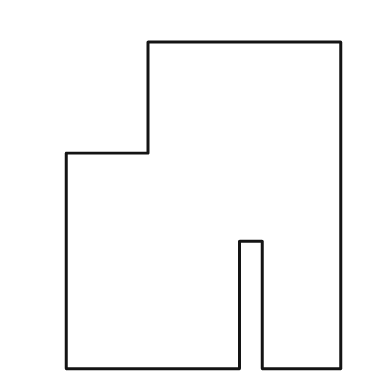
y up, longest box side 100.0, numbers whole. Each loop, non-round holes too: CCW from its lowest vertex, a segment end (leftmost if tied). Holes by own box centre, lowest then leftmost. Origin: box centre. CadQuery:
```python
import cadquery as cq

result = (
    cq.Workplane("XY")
    .moveTo(-42.0, -50.0)
    .lineTo(11.0, -50.0)
    .lineTo(11.0, -11.0)
    .lineTo(18.0, -11.0)
    .lineTo(18.0, -50.0)
    .lineTo(42.0, -50.0)
    .lineTo(42.0, 50.0)
    .lineTo(-17.0, 50.0)
    .lineTo(-17.0, 16.0)
    .lineTo(-42.0, 16.0)
    .close()
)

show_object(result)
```